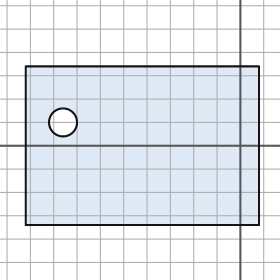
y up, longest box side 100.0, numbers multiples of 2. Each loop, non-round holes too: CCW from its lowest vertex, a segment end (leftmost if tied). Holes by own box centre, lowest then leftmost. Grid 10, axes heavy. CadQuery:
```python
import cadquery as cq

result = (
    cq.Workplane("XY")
    .moveTo(-92.0, -34.0)
    .lineTo(8.0, -34.0)
    .lineTo(8.0, 34.0)
    .lineTo(-92.0, 34.0)
    .close()
    .moveTo(-76.0, 10.0)
    .circle(6.0)
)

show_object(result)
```